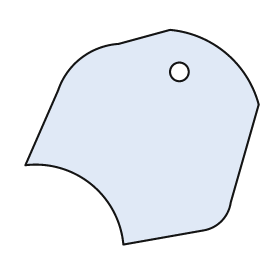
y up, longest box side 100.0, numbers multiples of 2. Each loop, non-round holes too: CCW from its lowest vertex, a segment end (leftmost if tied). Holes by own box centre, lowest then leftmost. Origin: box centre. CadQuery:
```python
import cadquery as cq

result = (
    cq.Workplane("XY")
    .moveTo(-8.0, -46.0)
    .lineTo(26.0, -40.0)
    .threePointArc((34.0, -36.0), (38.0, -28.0))
    .lineTo(50.0, 14.0)
    .threePointArc((36.0, 36.0), (12.0, 46.0))
    .lineTo(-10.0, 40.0)
    .threePointArc((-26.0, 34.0), (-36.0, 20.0))
    .lineTo(-50.0, -12.0)
    .threePointArc((-22.0, -20.0), (-8.0, -46.0))
    .close()
    .moveTo(16.0, 28.0)
    .circle(4.0)
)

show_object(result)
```